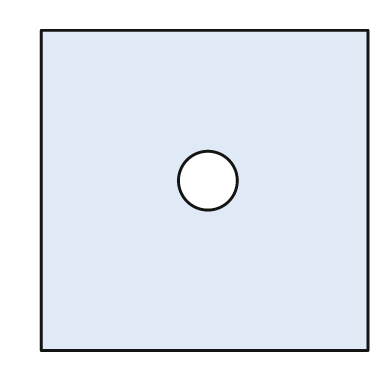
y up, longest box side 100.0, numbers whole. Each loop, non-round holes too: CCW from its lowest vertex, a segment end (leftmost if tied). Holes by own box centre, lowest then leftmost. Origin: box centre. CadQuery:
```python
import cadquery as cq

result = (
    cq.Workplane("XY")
    .moveTo(-50.0, -49.0)
    .lineTo(50.0, -49.0)
    .lineTo(50.0, 49.0)
    .lineTo(-50.0, 49.0)
    .close()
    .moveTo(1.0, 3.0)
    .circle(9.0)
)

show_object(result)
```